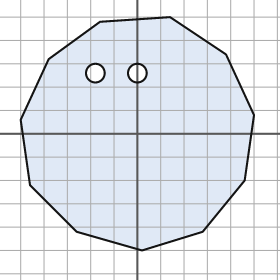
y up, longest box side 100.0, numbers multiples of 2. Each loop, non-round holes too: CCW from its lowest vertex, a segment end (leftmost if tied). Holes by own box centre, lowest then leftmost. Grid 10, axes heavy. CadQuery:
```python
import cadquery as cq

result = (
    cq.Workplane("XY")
    .moveTo(2.0, -50.0)
    .lineTo(28.0, -42.0)
    .lineTo(46.0, -20.0)
    .lineTo(50.0, 8.0)
    .lineTo(38.0, 34.0)
    .lineTo(14.0, 50.0)
    .lineTo(-16.0, 48.0)
    .lineTo(-38.0, 32.0)
    .lineTo(-50.0, 6.0)
    .lineTo(-46.0, -22.0)
    .lineTo(-26.0, -42.0)
    .close()
    .moveTo(-18.0, 26.0)
    .circle(4.0)
    .moveTo(0.0, 26.0)
    .circle(4.0)
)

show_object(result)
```